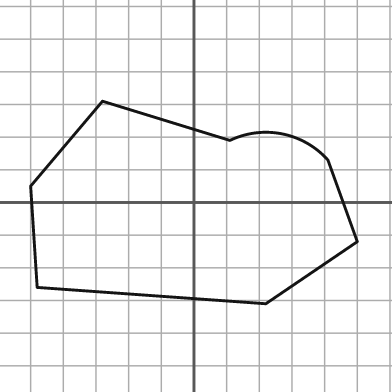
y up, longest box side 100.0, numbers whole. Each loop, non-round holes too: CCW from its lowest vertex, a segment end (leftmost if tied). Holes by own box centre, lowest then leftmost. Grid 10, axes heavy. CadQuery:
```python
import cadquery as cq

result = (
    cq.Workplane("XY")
    .moveTo(22.0, -31.0)
    .lineTo(50.0, -12.0)
    .lineTo(41.0, 13.0)
    .threePointArc((27.0, 21.0), (11.0, 19.0))
    .lineTo(-28.0, 31.0)
    .lineTo(-50.0, 5.0)
    .lineTo(-48.0, -26.0)
    .close()
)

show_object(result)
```